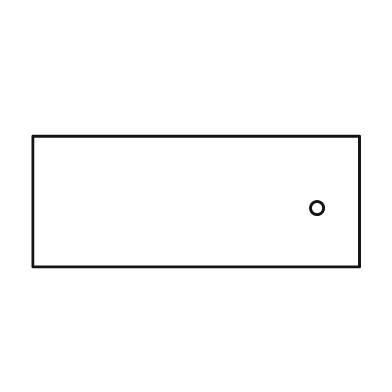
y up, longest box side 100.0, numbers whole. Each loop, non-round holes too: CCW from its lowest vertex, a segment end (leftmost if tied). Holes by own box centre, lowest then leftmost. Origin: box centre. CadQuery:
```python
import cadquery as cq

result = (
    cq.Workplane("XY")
    .moveTo(-50.0, -20.0)
    .lineTo(50.0, -20.0)
    .lineTo(50.0, 20.0)
    .lineTo(-50.0, 20.0)
    .close()
    .moveTo(37.0, -2.0)
    .circle(2.0)
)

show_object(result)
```